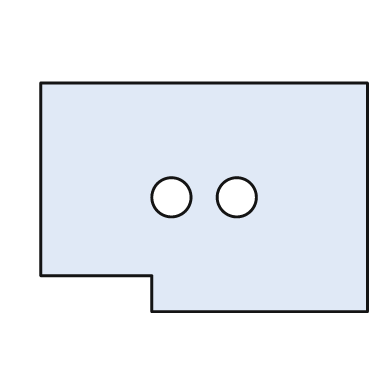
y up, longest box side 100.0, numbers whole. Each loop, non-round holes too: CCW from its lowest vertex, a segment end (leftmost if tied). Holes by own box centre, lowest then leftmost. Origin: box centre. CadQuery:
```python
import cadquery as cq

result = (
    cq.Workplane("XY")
    .moveTo(-16.0, -35.0)
    .lineTo(50.0, -35.0)
    .lineTo(50.0, 35.0)
    .lineTo(-50.0, 35.0)
    .lineTo(-50.0, -24.0)
    .lineTo(-16.0, -24.0)
    .close()
    .moveTo(-10.0, 0.0)
    .circle(6.0)
    .moveTo(10.0, 0.0)
    .circle(6.0)
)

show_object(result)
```